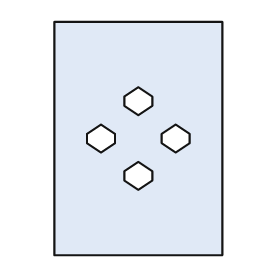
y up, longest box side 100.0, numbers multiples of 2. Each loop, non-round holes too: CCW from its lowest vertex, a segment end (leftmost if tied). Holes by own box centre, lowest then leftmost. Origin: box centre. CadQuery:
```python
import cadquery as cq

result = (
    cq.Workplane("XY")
    .moveTo(-36.0, -50.0)
    .lineTo(36.0, -50.0)
    .lineTo(36.0, 50.0)
    .lineTo(-36.0, 50.0)
    .close()
    .moveTo(0.0, -22.0)
    .lineTo(6.0, -18.0)
    .lineTo(6.0, -14.0)
    .lineTo(0.0, -10.0)
    .lineTo(-6.0, -14.0)
    .lineTo(-6.0, -18.0)
    .close()
    .moveTo(-16.0, -6.0)
    .lineTo(-10.0, -2.0)
    .lineTo(-10.0, 2.0)
    .lineTo(-16.0, 6.0)
    .lineTo(-22.0, 2.0)
    .lineTo(-22.0, -2.0)
    .close()
    .moveTo(16.0, -6.0)
    .lineTo(22.0, -2.0)
    .lineTo(22.0, 2.0)
    .lineTo(16.0, 6.0)
    .lineTo(10.0, 2.0)
    .lineTo(10.0, -2.0)
    .close()
    .moveTo(0.0, 10.0)
    .lineTo(6.0, 14.0)
    .lineTo(6.0, 18.0)
    .lineTo(0.0, 22.0)
    .lineTo(-6.0, 18.0)
    .lineTo(-6.0, 14.0)
    .close()
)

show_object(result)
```